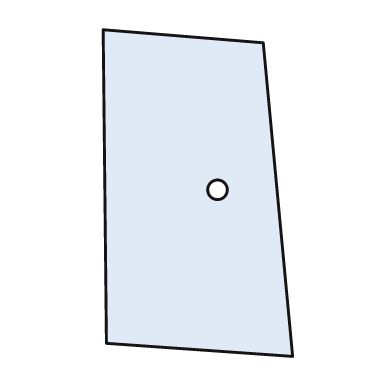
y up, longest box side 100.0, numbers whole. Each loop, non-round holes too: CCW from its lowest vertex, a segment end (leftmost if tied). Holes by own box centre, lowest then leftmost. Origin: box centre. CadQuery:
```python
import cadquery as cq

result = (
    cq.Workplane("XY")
    .moveTo(29.0, -50.0)
    .lineTo(20.0, 46.0)
    .lineTo(-29.0, 50.0)
    .lineTo(-28.0, -46.0)
    .close()
    .moveTo(6.0, 1.0)
    .circle(3.0)
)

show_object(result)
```